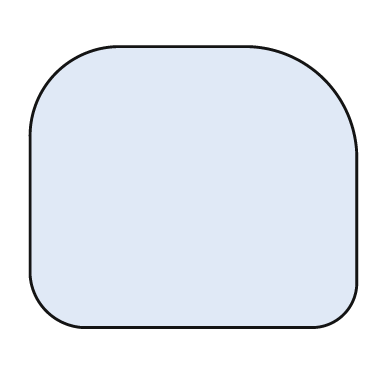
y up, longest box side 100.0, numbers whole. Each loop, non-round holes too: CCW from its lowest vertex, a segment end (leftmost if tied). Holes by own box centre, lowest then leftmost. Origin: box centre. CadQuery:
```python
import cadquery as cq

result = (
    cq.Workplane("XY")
    .moveTo(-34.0, -43.0)
    .lineTo(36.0, -43.0)
    .threePointArc((46.0, -39.0), (50.0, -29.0))
    .lineTo(50.0, 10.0)
    .threePointArc((40.0, 33.0), (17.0, 43.0))
    .lineTo(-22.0, 43.0)
    .threePointArc((-42.0, 35.0), (-50.0, 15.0))
    .lineTo(-50.0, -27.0)
    .threePointArc((-45.0, -38.0), (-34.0, -43.0))
    .close()
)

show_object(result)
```